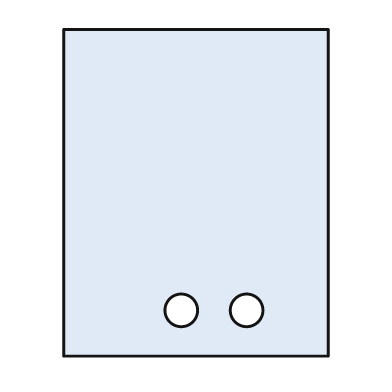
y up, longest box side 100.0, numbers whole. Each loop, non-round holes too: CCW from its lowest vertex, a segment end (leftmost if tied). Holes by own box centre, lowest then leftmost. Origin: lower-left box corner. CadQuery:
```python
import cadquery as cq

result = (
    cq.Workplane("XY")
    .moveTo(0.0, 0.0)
    .lineTo(81.0, 0.0)
    .lineTo(81.0, 100.0)
    .lineTo(0.0, 100.0)
    .close()
    .moveTo(36.0, 14.0)
    .circle(5.0)
    .moveTo(56.0, 14.0)
    .circle(5.0)
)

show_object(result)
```